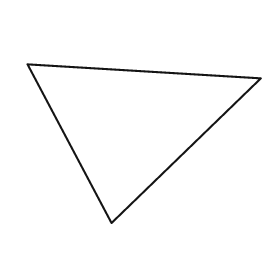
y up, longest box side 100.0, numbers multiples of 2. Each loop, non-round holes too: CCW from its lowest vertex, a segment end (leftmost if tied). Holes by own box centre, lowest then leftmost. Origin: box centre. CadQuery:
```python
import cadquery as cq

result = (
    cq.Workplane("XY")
    .moveTo(-14.0, -34.0)
    .lineTo(50.0, 28.0)
    .lineTo(-50.0, 34.0)
    .close()
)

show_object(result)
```